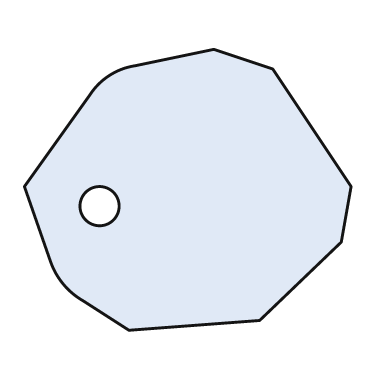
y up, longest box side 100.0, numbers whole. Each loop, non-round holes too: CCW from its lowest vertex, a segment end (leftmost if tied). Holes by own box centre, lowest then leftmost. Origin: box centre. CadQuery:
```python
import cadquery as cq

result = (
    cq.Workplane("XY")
    .moveTo(-18.0, -43.0)
    .lineTo(22.0, -40.0)
    .lineTo(47.0, -16.0)
    .lineTo(50.0, 1.0)
    .lineTo(26.0, 37.0)
    .lineTo(8.0, 43.0)
    .lineTo(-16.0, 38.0)
    .threePointArc((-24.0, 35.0), (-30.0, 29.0))
    .lineTo(-50.0, 1.0)
    .lineTo(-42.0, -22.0)
    .threePointArc((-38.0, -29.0), (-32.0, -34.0))
    .close()
    .moveTo(-27.0, -5.0)
    .circle(6.0)
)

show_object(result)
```